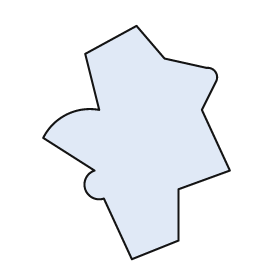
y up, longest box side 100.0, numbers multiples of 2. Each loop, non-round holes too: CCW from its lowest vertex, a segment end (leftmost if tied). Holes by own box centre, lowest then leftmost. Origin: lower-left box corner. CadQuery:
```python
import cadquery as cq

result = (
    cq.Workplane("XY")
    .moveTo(38.0, 0.0)
    .lineTo(58.0, 8.0)
    .lineTo(58.0, 30.0)
    .lineTo(80.0, 38.0)
    .lineTo(68.0, 64.0)
    .lineTo(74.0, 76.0)
    .threePointArc((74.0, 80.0), (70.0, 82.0))
    .lineTo(52.0, 86.0)
    .lineTo(40.0, 100.0)
    .lineTo(18.0, 88.0)
    .lineTo(24.0, 64.0)
    .threePointArc((10.0, 62.0), (0.0, 52.0))
    .lineTo(22.0, 38.0)
    .threePointArc((18.0, 30.0), (26.0, 26.0))
    .close()
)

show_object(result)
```